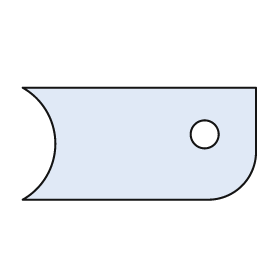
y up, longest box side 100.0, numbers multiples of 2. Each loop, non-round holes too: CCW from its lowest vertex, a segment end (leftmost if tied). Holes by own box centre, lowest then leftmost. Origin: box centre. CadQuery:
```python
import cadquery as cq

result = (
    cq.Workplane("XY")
    .moveTo(-50.0, -24.0)
    .lineTo(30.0, -24.0)
    .threePointArc((44.0, -18.0), (50.0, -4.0))
    .lineTo(50.0, 24.0)
    .lineTo(-50.0, 24.0)
    .threePointArc((-36.0, 0.0), (-50.0, -24.0))
    .close()
    .moveTo(28.0, 4.0)
    .circle(6.0)
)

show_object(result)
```